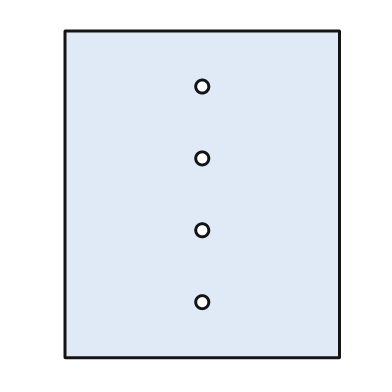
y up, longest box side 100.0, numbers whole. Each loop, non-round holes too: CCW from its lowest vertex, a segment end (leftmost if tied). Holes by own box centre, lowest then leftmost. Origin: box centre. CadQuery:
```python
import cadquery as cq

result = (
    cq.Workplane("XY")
    .moveTo(-42.0, -50.0)
    .lineTo(42.0, -50.0)
    .lineTo(42.0, 50.0)
    .lineTo(-42.0, 50.0)
    .close()
    .moveTo(0.0, -33.0)
    .circle(2.0)
    .moveTo(0.0, -11.0)
    .circle(2.0)
    .moveTo(0.0, 11.0)
    .circle(2.0)
    .moveTo(0.0, 33.0)
    .circle(2.0)
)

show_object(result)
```